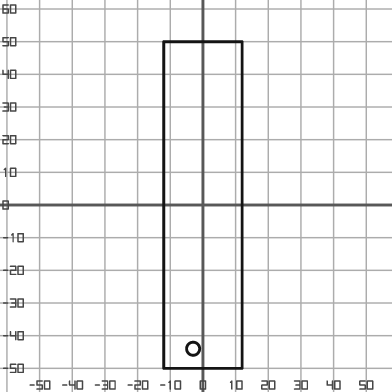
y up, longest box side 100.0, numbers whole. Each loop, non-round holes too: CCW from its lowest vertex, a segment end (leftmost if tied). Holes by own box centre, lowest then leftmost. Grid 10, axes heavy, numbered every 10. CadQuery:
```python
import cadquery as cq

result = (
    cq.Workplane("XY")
    .moveTo(-12.0, -50.0)
    .lineTo(12.0, -50.0)
    .lineTo(12.0, 50.0)
    .lineTo(-12.0, 50.0)
    .close()
    .moveTo(-3.0, -44.0)
    .circle(2.0)
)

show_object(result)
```